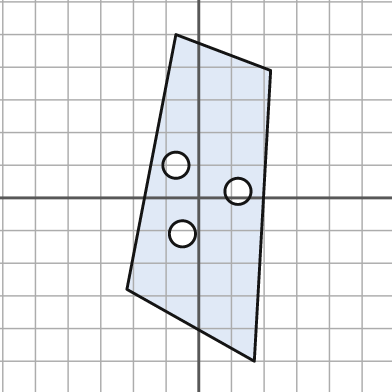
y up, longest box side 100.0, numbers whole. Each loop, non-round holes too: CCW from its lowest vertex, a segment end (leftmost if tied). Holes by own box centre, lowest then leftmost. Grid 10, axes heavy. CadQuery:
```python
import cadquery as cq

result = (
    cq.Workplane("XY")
    .moveTo(17.0, -50.0)
    .lineTo(22.0, 39.0)
    .lineTo(-7.0, 50.0)
    .lineTo(-22.0, -28.0)
    .close()
    .moveTo(-5.0, -11.0)
    .circle(4.0)
    .moveTo(12.0, 2.0)
    .circle(4.0)
    .moveTo(-7.0, 10.0)
    .circle(4.0)
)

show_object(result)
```